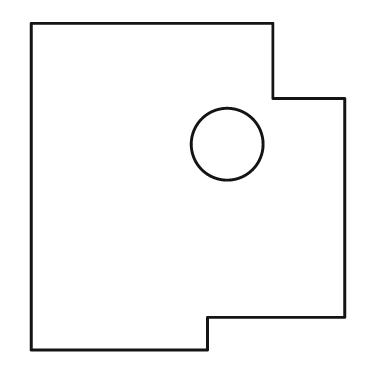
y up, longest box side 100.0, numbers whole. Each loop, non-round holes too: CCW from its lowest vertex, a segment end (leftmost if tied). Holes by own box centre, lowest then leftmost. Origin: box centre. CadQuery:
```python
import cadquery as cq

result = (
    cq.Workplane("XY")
    .moveTo(-48.0, -50.0)
    .lineTo(6.0, -50.0)
    .lineTo(6.0, -40.0)
    .lineTo(48.0, -40.0)
    .lineTo(48.0, 27.0)
    .lineTo(26.0, 27.0)
    .lineTo(26.0, 50.0)
    .lineTo(-48.0, 50.0)
    .close()
    .moveTo(12.0, 13.0)
    .circle(11.0)
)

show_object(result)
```